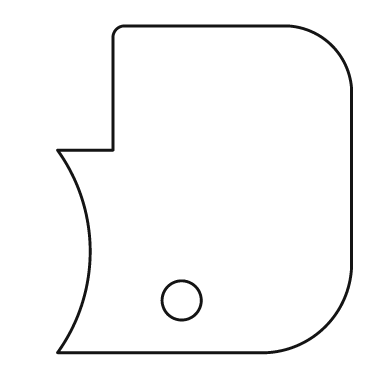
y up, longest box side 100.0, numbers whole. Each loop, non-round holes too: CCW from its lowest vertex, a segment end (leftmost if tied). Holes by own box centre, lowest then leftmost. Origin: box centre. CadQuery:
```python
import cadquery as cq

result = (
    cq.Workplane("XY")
    .moveTo(-45.0, -50.0)
    .lineTo(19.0, -50.0)
    .threePointArc((37.0, -42.0), (45.0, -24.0))
    .lineTo(45.0, 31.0)
    .threePointArc((39.0, 44.0), (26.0, 50.0))
    .lineTo(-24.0, 50.0)
    .threePointArc((-27.0, 49.0), (-28.0, 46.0))
    .lineTo(-28.0, 12.0)
    .lineTo(-45.0, 12.0)
    .threePointArc((-35.0, -19.0), (-45.0, -50.0))
    .close()
    .moveTo(-7.0, -34.0)
    .circle(6.0)
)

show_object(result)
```